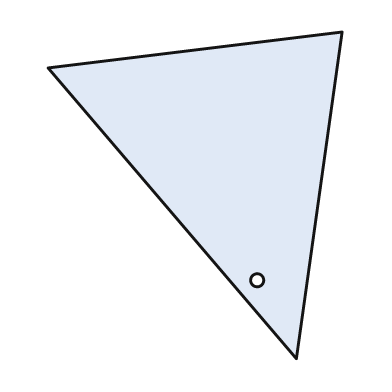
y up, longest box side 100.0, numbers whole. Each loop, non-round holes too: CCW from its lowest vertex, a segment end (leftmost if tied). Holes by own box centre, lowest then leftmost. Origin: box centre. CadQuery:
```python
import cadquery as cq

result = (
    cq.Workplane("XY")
    .moveTo(31.0, -50.0)
    .lineTo(45.0, 50.0)
    .lineTo(-45.0, 39.0)
    .close()
    .moveTo(19.0, -26.0)
    .circle(2.0)
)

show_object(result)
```